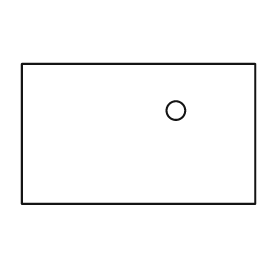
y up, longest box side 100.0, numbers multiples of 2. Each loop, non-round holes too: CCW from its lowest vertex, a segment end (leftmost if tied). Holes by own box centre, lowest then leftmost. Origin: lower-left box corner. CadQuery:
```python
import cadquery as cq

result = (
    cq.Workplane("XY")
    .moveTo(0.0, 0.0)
    .lineTo(100.0, 0.0)
    .lineTo(100.0, 60.0)
    .lineTo(0.0, 60.0)
    .close()
    .moveTo(66.0, 40.0)
    .circle(4.0)
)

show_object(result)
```